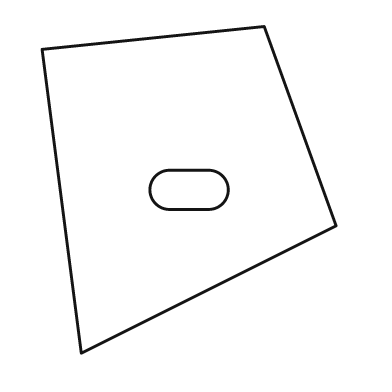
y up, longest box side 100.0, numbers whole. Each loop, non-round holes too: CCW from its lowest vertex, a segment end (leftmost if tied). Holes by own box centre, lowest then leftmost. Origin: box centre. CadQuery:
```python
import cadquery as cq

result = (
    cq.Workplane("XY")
    .moveTo(-33.0, -50.0)
    .lineTo(45.0, -11.0)
    .lineTo(23.0, 50.0)
    .lineTo(-45.0, 43.0)
    .close()
    .moveTo(-6.0, -6.0)
    .lineTo(6.0, -6.0)
    .threePointArc((12.0, 0.0), (6.0, 6.0))
    .lineTo(-6.0, 6.0)
    .threePointArc((-12.0, 0.0), (-6.0, -6.0))
    .close()
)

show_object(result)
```